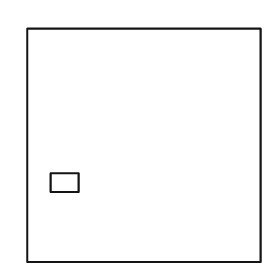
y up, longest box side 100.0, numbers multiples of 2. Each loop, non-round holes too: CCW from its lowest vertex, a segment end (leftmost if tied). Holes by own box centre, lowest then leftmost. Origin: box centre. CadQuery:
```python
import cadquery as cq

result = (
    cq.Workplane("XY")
    .moveTo(-50.0, -50.0)
    .lineTo(50.0, -50.0)
    .lineTo(50.0, 50.0)
    .lineTo(-50.0, 50.0)
    .close()
    .moveTo(-40.0, -20.0)
    .lineTo(-28.0, -20.0)
    .lineTo(-28.0, -12.0)
    .lineTo(-40.0, -12.0)
    .close()
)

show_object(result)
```